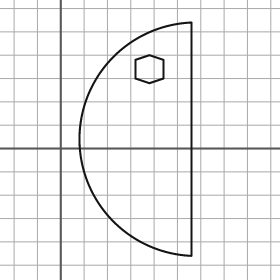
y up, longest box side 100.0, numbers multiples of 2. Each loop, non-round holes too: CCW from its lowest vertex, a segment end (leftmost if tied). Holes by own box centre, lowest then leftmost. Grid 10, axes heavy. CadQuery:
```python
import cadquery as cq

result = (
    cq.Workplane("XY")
    .moveTo(56.0, -46.0)
    .lineTo(56.0, 54.0)
    .threePointArc((8.0, 4.0), (56.0, -46.0))
    .close()
    .moveTo(38.0, 28.0)
    .lineTo(44.0, 30.0)
    .lineTo(44.0, 38.0)
    .lineTo(38.0, 40.0)
    .lineTo(32.0, 38.0)
    .lineTo(32.0, 30.0)
    .close()
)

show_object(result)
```